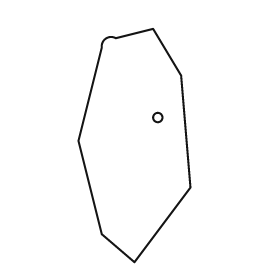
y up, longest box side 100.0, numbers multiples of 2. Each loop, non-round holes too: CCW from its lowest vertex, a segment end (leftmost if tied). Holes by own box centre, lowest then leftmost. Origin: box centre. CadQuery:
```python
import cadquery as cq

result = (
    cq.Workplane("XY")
    .moveTo(0.0, -50.0)
    .lineTo(24.0, -18.0)
    .lineTo(20.0, 30.0)
    .lineTo(8.0, 50.0)
    .lineTo(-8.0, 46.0)
    .threePointArc((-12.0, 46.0), (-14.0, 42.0))
    .lineTo(-24.0, 2.0)
    .lineTo(-14.0, -38.0)
    .close()
    .moveTo(10.0, 12.0)
    .circle(2.0)
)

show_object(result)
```